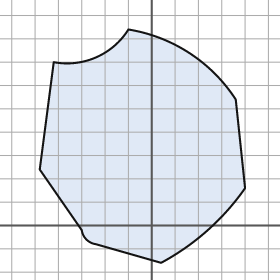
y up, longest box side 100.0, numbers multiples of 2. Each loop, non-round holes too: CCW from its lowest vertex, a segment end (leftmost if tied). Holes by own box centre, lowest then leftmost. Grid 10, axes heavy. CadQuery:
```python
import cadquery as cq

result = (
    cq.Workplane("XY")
    .moveTo(4.0, -16.0)
    .threePointArc((24.0, -2.0), (40.0, 16.0))
    .lineTo(36.0, 54.0)
    .threePointArc((16.0, 74.0), (-10.0, 84.0))
    .threePointArc((-24.0, 72.0), (-42.0, 70.0))
    .lineTo(-48.0, 24.0)
    .lineTo(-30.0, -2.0)
    .threePointArc((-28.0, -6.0), (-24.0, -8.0))
    .close()
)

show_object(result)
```